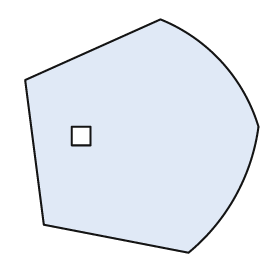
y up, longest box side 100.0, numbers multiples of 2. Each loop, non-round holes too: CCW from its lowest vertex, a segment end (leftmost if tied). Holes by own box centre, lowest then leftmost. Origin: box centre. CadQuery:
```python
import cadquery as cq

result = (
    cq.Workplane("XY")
    .moveTo(20.0, -50.0)
    .threePointArc((40.0, -26.0), (50.0, 4.0))
    .threePointArc((34.0, 32.0), (8.0, 50.0))
    .lineTo(-50.0, 24.0)
    .lineTo(-42.0, -38.0)
    .close()
    .moveTo(-30.0, -4.0)
    .lineTo(-22.0, -4.0)
    .lineTo(-22.0, 4.0)
    .lineTo(-30.0, 4.0)
    .close()
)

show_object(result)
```